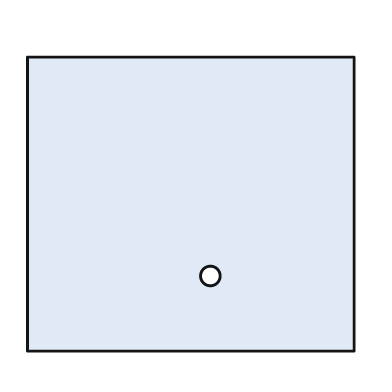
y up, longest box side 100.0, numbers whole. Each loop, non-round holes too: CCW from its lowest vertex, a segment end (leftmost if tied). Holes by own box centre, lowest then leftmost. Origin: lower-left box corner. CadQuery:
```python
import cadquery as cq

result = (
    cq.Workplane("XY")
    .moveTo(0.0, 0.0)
    .lineTo(100.0, 0.0)
    .lineTo(100.0, 90.0)
    .lineTo(0.0, 90.0)
    .close()
    .moveTo(56.0, 23.0)
    .circle(3.0)
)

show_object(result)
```